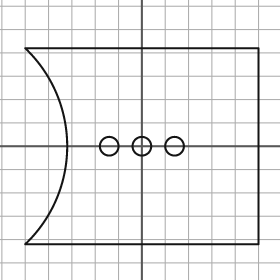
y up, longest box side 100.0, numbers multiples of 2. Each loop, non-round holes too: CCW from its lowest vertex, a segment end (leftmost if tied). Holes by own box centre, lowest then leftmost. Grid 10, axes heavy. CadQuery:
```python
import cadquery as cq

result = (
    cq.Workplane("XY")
    .moveTo(-50.0, -42.0)
    .lineTo(50.0, -42.0)
    .lineTo(50.0, 42.0)
    .lineTo(-50.0, 42.0)
    .threePointArc((-32.0, 0.0), (-50.0, -42.0))
    .close()
    .moveTo(-14.0, 0.0)
    .circle(4.0)
    .moveTo(0.0, 0.0)
    .circle(4.0)
    .moveTo(14.0, 0.0)
    .circle(4.0)
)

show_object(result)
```